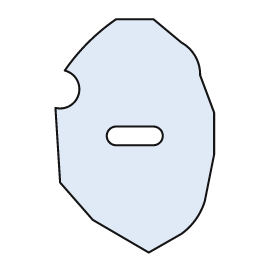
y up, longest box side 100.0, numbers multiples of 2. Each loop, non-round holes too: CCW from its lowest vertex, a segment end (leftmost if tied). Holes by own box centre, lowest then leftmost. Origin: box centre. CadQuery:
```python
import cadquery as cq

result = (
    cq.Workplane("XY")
    .moveTo(6.0, -50.0)
    .lineTo(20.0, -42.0)
    .threePointArc((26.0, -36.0), (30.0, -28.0))
    .lineTo(34.0, -8.0)
    .lineTo(34.0, 10.0)
    .lineTo(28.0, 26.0)
    .threePointArc((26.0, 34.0), (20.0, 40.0))
    .lineTo(8.0, 50.0)
    .lineTo(-8.0, 50.0)
    .threePointArc((-20.0, 40.0), (-30.0, 28.0))
    .threePointArc((-24.0, 18.0), (-34.0, 12.0))
    .lineTo(-32.0, -20.0)
    .lineTo(-18.0, -36.0)
    .close()
    .moveTo(-8.0, -4.0)
    .lineTo(8.0, -4.0)
    .threePointArc((12.0, 0.0), (8.0, 4.0))
    .lineTo(-8.0, 4.0)
    .threePointArc((-12.0, 0.0), (-8.0, -4.0))
    .close()
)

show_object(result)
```